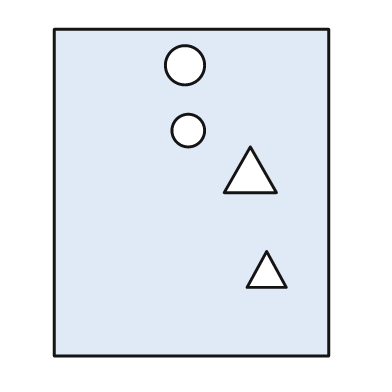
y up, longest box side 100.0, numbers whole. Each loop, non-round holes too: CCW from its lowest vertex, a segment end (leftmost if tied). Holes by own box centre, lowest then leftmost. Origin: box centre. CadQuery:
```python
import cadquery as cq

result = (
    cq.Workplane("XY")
    .moveTo(-42.0, -50.0)
    .lineTo(42.0, -50.0)
    .lineTo(42.0, 50.0)
    .lineTo(-42.0, 50.0)
    .close()
    .moveTo(17.0, -29.0)
    .lineTo(29.0, -29.0)
    .lineTo(23.0, -18.0)
    .close()
    .moveTo(10.0, 0.0)
    .lineTo(26.0, 0.0)
    .lineTo(18.0, 14.0)
    .close()
    .moveTo(-1.0, 19.0)
    .circle(5.0)
    .moveTo(-2.0, 39.0)
    .circle(6.0)
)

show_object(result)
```